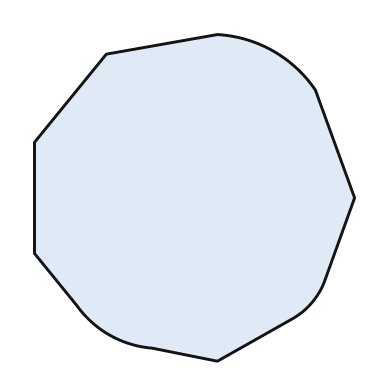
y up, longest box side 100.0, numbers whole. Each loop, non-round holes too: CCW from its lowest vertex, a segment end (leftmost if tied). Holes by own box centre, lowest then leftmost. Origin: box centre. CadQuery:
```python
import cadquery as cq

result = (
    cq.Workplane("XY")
    .moveTo(7.0, -50.0)
    .lineTo(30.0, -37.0)
    .threePointArc((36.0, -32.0), (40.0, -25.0))
    .lineTo(49.0, 0.0)
    .lineTo(37.0, 33.0)
    .threePointArc((24.0, 45.0), (7.0, 50.0))
    .lineTo(-27.0, 44.0)
    .lineTo(-49.0, 17.0)
    .lineTo(-49.0, -17.0)
    .lineTo(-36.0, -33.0)
    .threePointArc((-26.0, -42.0), (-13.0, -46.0))
    .close()
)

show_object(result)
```